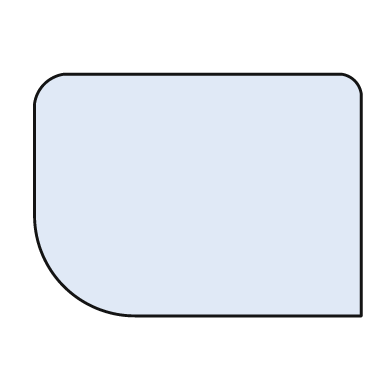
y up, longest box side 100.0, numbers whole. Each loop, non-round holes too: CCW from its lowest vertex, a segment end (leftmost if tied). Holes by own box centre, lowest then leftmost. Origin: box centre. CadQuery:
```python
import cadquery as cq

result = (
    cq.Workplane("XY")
    .moveTo(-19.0, -37.0)
    .lineTo(50.0, -37.0)
    .lineTo(50.0, 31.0)
    .threePointArc((48.0, 35.0), (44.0, 37.0))
    .lineTo(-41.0, 37.0)
    .threePointArc((-47.0, 34.0), (-50.0, 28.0))
    .lineTo(-50.0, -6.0)
    .threePointArc((-41.0, -28.0), (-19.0, -37.0))
    .close()
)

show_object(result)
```